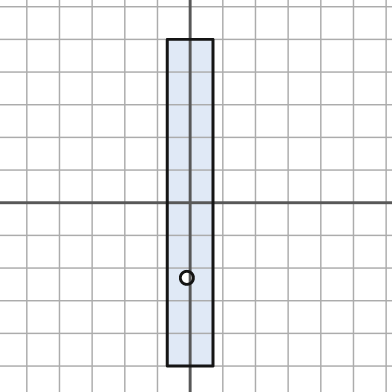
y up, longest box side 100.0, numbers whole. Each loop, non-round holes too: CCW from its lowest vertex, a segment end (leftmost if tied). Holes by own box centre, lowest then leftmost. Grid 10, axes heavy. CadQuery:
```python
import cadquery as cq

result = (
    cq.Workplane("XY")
    .moveTo(-7.0, -50.0)
    .lineTo(7.0, -50.0)
    .lineTo(7.0, 50.0)
    .lineTo(-7.0, 50.0)
    .close()
    .moveTo(-1.0, -23.0)
    .circle(2.0)
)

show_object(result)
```